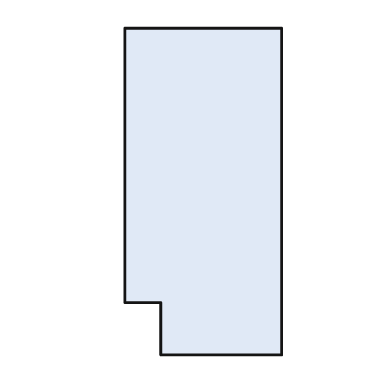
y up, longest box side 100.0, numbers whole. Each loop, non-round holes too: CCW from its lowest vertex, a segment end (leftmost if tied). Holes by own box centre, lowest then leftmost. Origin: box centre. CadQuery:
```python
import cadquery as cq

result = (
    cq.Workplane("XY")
    .moveTo(-13.0, -50.0)
    .lineTo(24.0, -50.0)
    .lineTo(24.0, 50.0)
    .lineTo(-24.0, 50.0)
    .lineTo(-24.0, -34.0)
    .lineTo(-13.0, -34.0)
    .close()
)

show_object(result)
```